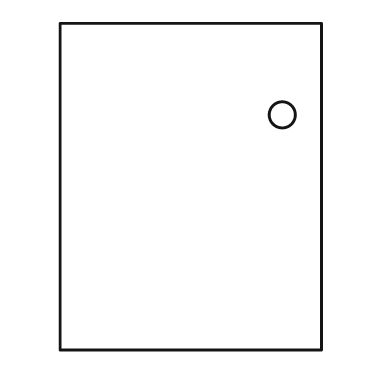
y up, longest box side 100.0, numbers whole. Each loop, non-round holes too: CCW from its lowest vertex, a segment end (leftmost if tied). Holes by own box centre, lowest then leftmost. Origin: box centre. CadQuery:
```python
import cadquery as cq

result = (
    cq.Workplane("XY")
    .moveTo(-40.0, -50.0)
    .lineTo(40.0, -50.0)
    .lineTo(40.0, 50.0)
    .lineTo(-40.0, 50.0)
    .close()
    .moveTo(28.0, 22.0)
    .circle(4.0)
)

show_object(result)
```